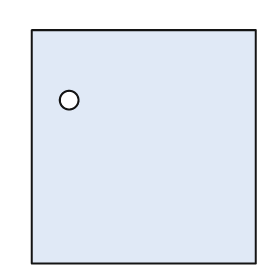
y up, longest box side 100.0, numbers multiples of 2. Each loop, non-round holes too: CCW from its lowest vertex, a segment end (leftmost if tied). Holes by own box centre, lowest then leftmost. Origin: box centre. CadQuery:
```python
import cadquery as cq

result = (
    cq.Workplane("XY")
    .moveTo(-48.0, -50.0)
    .lineTo(48.0, -50.0)
    .lineTo(48.0, 50.0)
    .lineTo(-48.0, 50.0)
    .close()
    .moveTo(-32.0, 20.0)
    .circle(4.0)
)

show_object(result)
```